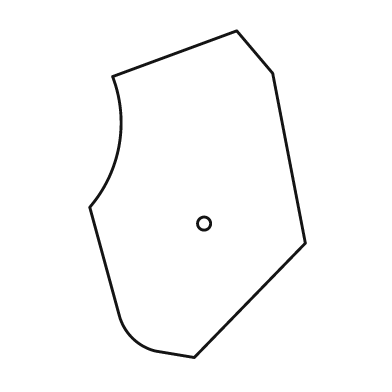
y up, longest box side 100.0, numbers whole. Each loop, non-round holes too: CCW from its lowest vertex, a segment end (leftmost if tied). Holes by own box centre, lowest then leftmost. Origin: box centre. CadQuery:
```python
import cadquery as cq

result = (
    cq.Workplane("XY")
    .moveTo(-1.0, -50.0)
    .lineTo(33.0, -15.0)
    .lineTo(23.0, 37.0)
    .lineTo(12.0, 50.0)
    .lineTo(-26.0, 36.0)
    .threePointArc((-24.0, 15.0), (-33.0, -4.0))
    .lineTo(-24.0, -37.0)
    .threePointArc((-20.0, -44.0), (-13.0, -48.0))
    .close()
    .moveTo(2.0, -9.0)
    .circle(2.0)
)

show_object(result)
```